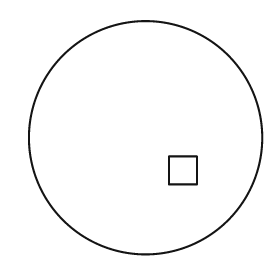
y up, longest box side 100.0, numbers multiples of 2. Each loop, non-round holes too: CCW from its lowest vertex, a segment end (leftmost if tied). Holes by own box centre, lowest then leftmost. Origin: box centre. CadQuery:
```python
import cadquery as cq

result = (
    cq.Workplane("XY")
    .moveTo(0.0, 0.0)
    .circle(50.0)
    .moveTo(10.0, -20.0)
    .lineTo(22.0, -20.0)
    .lineTo(22.0, -8.0)
    .lineTo(10.0, -8.0)
    .close()
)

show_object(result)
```